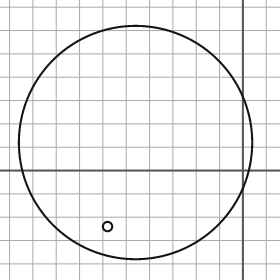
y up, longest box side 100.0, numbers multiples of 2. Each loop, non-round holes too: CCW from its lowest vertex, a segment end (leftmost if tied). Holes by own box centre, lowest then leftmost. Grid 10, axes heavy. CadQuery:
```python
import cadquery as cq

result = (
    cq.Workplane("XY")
    .moveTo(-46.0, 12.0)
    .circle(50.0)
    .moveTo(-58.0, -24.0)
    .circle(2.0)
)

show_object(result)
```